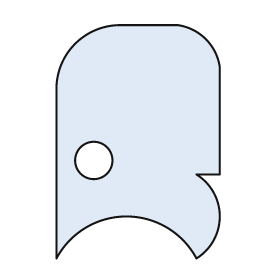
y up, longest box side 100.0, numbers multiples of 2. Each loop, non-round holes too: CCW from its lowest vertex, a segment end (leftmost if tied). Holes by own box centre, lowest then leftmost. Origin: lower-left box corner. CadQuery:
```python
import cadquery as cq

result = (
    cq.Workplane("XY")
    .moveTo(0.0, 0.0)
    .threePointArc((30.0, 18.0), (60.0, 0.0))
    .threePointArc((70.0, 18.0), (60.0, 36.0))
    .lineTo(70.0, 36.0)
    .lineTo(70.0, 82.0)
    .threePointArc((64.0, 94.0), (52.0, 100.0))
    .lineTo(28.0, 100.0)
    .threePointArc((8.0, 92.0), (0.0, 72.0))
    .close()
    .moveTo(16.0, 42.0)
    .circle(8.0)
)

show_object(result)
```